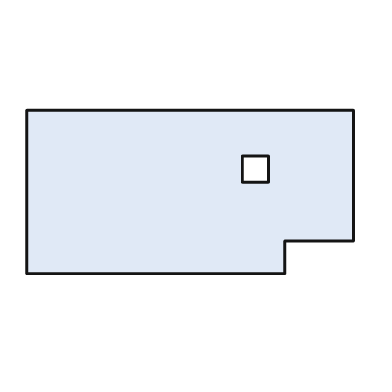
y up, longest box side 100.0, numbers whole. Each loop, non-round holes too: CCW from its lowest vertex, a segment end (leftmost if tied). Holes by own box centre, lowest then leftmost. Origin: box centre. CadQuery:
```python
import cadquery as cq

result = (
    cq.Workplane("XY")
    .moveTo(-50.0, -25.0)
    .lineTo(29.0, -25.0)
    .lineTo(29.0, -15.0)
    .lineTo(50.0, -15.0)
    .lineTo(50.0, 25.0)
    .lineTo(-50.0, 25.0)
    .close()
    .moveTo(16.0, 3.0)
    .lineTo(24.0, 3.0)
    .lineTo(24.0, 11.0)
    .lineTo(16.0, 11.0)
    .close()
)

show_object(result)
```